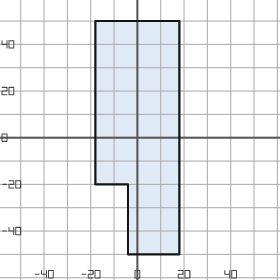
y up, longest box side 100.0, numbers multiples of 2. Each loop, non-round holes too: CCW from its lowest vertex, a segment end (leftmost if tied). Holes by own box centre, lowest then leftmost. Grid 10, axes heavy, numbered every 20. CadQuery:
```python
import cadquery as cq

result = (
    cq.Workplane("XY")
    .moveTo(-4.0, -50.0)
    .lineTo(18.0, -50.0)
    .lineTo(18.0, 50.0)
    .lineTo(-18.0, 50.0)
    .lineTo(-18.0, -20.0)
    .lineTo(-4.0, -20.0)
    .close()
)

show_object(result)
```